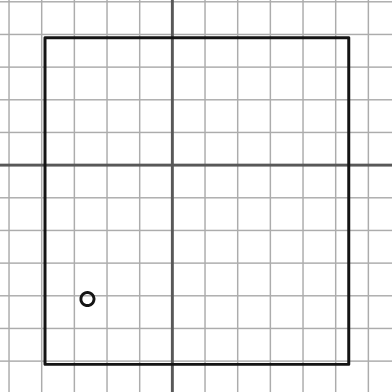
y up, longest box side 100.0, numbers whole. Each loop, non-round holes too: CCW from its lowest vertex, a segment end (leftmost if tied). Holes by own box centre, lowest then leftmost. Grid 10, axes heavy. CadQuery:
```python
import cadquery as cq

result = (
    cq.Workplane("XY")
    .moveTo(-39.0, -61.0)
    .lineTo(54.0, -61.0)
    .lineTo(54.0, 39.0)
    .lineTo(-39.0, 39.0)
    .close()
    .moveTo(-26.0, -41.0)
    .circle(2.0)
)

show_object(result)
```